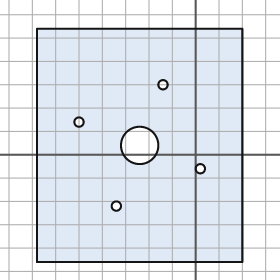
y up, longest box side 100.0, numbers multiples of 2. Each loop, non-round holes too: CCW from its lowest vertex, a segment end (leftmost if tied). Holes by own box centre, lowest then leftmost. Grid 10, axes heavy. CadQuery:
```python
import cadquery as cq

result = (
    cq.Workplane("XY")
    .moveTo(-68.0, -46.0)
    .lineTo(20.0, -46.0)
    .lineTo(20.0, 54.0)
    .lineTo(-68.0, 54.0)
    .close()
    .moveTo(-34.0, -22.0)
    .circle(2.0)
    .moveTo(2.0, -6.0)
    .circle(2.0)
    .moveTo(-24.0, 4.0)
    .circle(8.0)
    .moveTo(-50.0, 14.0)
    .circle(2.0)
    .moveTo(-14.0, 30.0)
    .circle(2.0)
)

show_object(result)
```